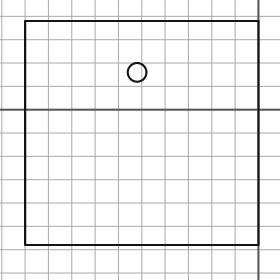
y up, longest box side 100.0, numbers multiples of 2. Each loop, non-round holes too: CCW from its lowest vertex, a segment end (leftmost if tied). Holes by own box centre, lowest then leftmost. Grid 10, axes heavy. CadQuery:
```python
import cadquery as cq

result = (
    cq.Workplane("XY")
    .moveTo(-100.0, -58.0)
    .lineTo(0.0, -58.0)
    .lineTo(0.0, 38.0)
    .lineTo(-100.0, 38.0)
    .close()
    .moveTo(-52.0, 16.0)
    .circle(4.0)
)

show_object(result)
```